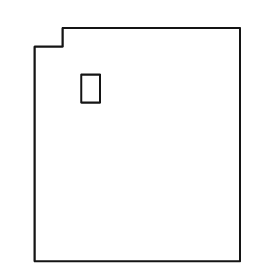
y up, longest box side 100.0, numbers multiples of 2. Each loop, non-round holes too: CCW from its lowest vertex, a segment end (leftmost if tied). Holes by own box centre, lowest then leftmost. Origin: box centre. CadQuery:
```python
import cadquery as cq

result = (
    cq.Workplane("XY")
    .moveTo(-44.0, -50.0)
    .lineTo(44.0, -50.0)
    .lineTo(44.0, 50.0)
    .lineTo(-32.0, 50.0)
    .lineTo(-32.0, 42.0)
    .lineTo(-44.0, 42.0)
    .close()
    .moveTo(-24.0, 18.0)
    .lineTo(-16.0, 18.0)
    .lineTo(-16.0, 30.0)
    .lineTo(-24.0, 30.0)
    .close()
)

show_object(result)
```